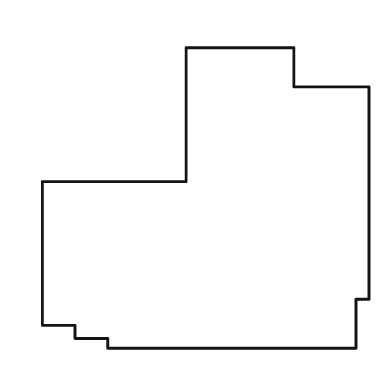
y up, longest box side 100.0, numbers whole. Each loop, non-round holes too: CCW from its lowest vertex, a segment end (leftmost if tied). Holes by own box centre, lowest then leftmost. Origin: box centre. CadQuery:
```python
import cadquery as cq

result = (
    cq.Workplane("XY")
    .moveTo(-30.0, -46.0)
    .lineTo(46.0, -46.0)
    .lineTo(46.0, -31.0)
    .lineTo(50.0, -31.0)
    .lineTo(50.0, 34.0)
    .lineTo(27.0, 34.0)
    .lineTo(27.0, 46.0)
    .lineTo(-6.0, 46.0)
    .lineTo(-6.0, 5.0)
    .lineTo(-50.0, 5.0)
    .lineTo(-50.0, -39.0)
    .lineTo(-40.0, -39.0)
    .lineTo(-40.0, -43.0)
    .lineTo(-30.0, -43.0)
    .close()
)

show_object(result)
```